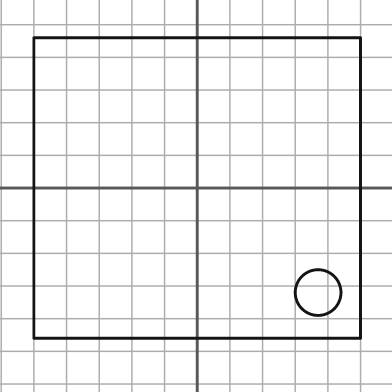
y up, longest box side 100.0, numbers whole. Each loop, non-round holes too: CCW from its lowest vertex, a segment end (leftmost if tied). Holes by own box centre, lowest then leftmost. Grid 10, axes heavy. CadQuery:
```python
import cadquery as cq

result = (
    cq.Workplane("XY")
    .moveTo(-50.0, -46.0)
    .lineTo(50.0, -46.0)
    .lineTo(50.0, 46.0)
    .lineTo(-50.0, 46.0)
    .close()
    .moveTo(37.0, -32.0)
    .circle(7.0)
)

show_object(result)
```